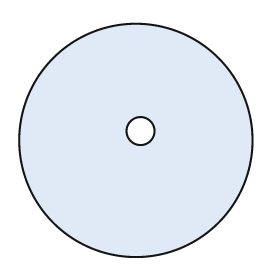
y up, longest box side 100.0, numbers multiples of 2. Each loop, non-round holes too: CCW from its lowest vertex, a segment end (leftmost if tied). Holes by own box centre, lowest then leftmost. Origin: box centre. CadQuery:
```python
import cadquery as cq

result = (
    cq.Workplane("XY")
    .moveTo(0.0, 0.0)
    .circle(50.0)
    .moveTo(2.0, 4.0)
    .circle(6.0)
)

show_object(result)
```